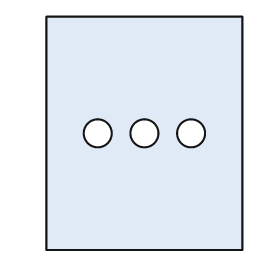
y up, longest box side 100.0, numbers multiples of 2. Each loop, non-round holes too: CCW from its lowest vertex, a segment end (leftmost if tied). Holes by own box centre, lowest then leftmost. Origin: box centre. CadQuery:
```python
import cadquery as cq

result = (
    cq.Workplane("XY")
    .moveTo(-42.0, -50.0)
    .lineTo(42.0, -50.0)
    .lineTo(42.0, 50.0)
    .lineTo(-42.0, 50.0)
    .close()
    .moveTo(-20.0, 0.0)
    .circle(6.0)
    .moveTo(0.0, 0.0)
    .circle(6.0)
    .moveTo(20.0, 0.0)
    .circle(6.0)
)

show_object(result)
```